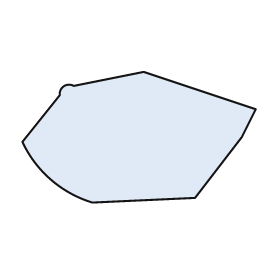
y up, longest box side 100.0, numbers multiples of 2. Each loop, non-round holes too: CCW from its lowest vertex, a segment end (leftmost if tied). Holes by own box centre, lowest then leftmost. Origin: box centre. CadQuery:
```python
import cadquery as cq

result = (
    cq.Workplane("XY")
    .moveTo(-20.0, -28.0)
    .lineTo(24.0, -26.0)
    .lineTo(44.0, 0.0)
    .lineTo(50.0, 12.0)
    .lineTo(2.0, 28.0)
    .lineTo(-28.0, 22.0)
    .threePointArc((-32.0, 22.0), (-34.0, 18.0))
    .lineTo(-50.0, -2.0)
    .threePointArc((-38.0, -18.0), (-20.0, -28.0))
    .close()
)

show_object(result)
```